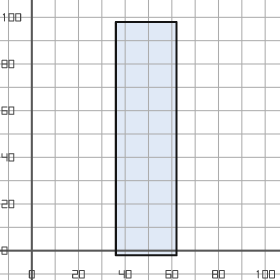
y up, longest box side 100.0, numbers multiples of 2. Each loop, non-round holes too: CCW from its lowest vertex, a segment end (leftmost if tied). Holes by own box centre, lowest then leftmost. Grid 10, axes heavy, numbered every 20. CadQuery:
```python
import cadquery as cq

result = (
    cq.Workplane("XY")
    .moveTo(36.0, -2.0)
    .lineTo(62.0, -2.0)
    .lineTo(62.0, 98.0)
    .lineTo(36.0, 98.0)
    .close()
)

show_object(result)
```